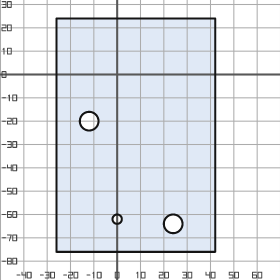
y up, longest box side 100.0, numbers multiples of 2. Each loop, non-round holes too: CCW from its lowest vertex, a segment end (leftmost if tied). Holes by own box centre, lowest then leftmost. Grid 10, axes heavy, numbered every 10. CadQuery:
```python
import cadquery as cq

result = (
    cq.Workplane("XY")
    .moveTo(-26.0, -76.0)
    .lineTo(42.0, -76.0)
    .lineTo(42.0, 24.0)
    .lineTo(-26.0, 24.0)
    .close()
    .moveTo(24.0, -64.0)
    .circle(4.0)
    .moveTo(0.0, -62.0)
    .circle(2.0)
    .moveTo(-12.0, -20.0)
    .circle(4.0)
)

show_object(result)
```